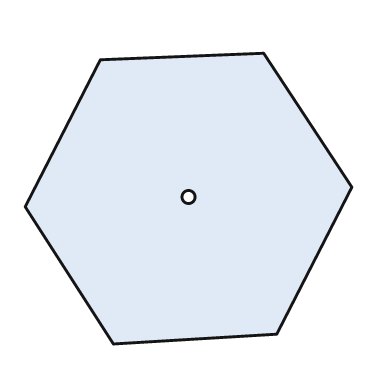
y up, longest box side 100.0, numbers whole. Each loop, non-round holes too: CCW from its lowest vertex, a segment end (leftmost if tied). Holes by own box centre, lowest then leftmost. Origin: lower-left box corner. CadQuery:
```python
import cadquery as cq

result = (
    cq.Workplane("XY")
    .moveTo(27.0, 0.0)
    .lineTo(77.0, 3.0)
    .lineTo(100.0, 48.0)
    .lineTo(73.0, 89.0)
    .lineTo(23.0, 87.0)
    .lineTo(0.0, 42.0)
    .close()
    .moveTo(50.0, 45.0)
    .circle(2.0)
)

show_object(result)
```